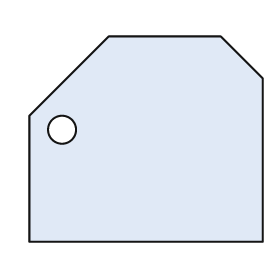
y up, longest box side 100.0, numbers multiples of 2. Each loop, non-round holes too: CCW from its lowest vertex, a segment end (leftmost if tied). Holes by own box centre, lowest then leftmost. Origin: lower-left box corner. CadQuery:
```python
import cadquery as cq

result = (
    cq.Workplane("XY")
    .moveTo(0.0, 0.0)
    .lineTo(100.0, 0.0)
    .lineTo(100.0, 70.0)
    .lineTo(82.0, 88.0)
    .lineTo(34.0, 88.0)
    .lineTo(0.0, 54.0)
    .close()
    .moveTo(14.0, 48.0)
    .circle(6.0)
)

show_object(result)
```